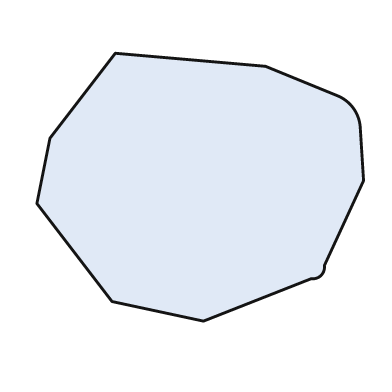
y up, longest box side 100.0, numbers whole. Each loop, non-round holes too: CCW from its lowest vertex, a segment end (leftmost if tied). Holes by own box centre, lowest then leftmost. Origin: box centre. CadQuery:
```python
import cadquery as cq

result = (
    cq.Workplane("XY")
    .moveTo(1.0, -41.0)
    .lineTo(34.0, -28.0)
    .threePointArc((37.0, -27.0), (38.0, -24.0))
    .lineTo(50.0, 2.0)
    .lineTo(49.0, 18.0)
    .threePointArc((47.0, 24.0), (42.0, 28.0))
    .lineTo(20.0, 37.0)
    .lineTo(-26.0, 41.0)
    .lineTo(-46.0, 15.0)
    .lineTo(-50.0, -5.0)
    .lineTo(-27.0, -35.0)
    .close()
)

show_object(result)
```